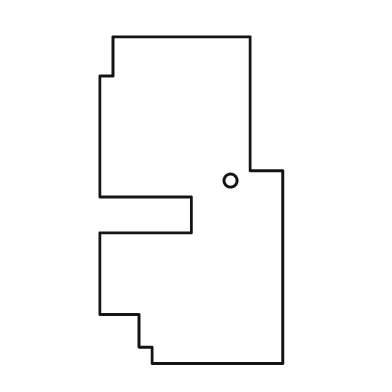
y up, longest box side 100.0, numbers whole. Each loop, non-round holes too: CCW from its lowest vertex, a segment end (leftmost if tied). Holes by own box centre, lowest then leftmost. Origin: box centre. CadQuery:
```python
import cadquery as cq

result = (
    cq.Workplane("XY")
    .moveTo(-12.0, -50.0)
    .lineTo(28.0, -50.0)
    .lineTo(28.0, 9.0)
    .lineTo(18.0, 9.0)
    .lineTo(18.0, 50.0)
    .lineTo(-24.0, 50.0)
    .lineTo(-24.0, 38.0)
    .lineTo(-28.0, 38.0)
    .lineTo(-28.0, 1.0)
    .lineTo(0.0, 1.0)
    .lineTo(0.0, -10.0)
    .lineTo(-28.0, -10.0)
    .lineTo(-28.0, -35.0)
    .lineTo(-16.0, -35.0)
    .lineTo(-16.0, -45.0)
    .lineTo(-12.0, -45.0)
    .close()
    .moveTo(12.0, 6.0)
    .circle(2.0)
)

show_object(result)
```